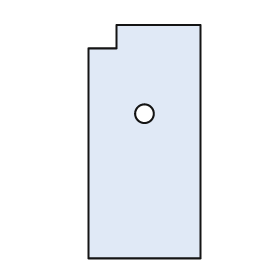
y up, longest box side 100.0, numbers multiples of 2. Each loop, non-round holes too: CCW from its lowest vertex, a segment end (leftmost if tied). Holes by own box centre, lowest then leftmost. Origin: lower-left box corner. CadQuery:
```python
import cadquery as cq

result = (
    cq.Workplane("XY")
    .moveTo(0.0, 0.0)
    .lineTo(48.0, 0.0)
    .lineTo(48.0, 100.0)
    .lineTo(12.0, 100.0)
    .lineTo(12.0, 90.0)
    .lineTo(0.0, 90.0)
    .close()
    .moveTo(24.0, 62.0)
    .circle(4.0)
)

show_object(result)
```